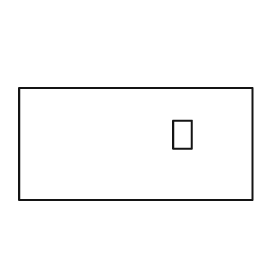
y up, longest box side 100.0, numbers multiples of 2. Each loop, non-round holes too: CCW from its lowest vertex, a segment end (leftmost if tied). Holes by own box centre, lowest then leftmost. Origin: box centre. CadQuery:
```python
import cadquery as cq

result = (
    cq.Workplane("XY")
    .moveTo(-50.0, -24.0)
    .lineTo(50.0, -24.0)
    .lineTo(50.0, 24.0)
    .lineTo(-50.0, 24.0)
    .close()
    .moveTo(16.0, -2.0)
    .lineTo(24.0, -2.0)
    .lineTo(24.0, 10.0)
    .lineTo(16.0, 10.0)
    .close()
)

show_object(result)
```